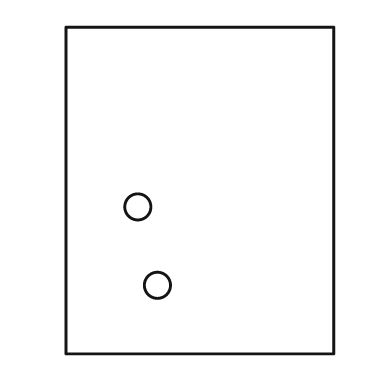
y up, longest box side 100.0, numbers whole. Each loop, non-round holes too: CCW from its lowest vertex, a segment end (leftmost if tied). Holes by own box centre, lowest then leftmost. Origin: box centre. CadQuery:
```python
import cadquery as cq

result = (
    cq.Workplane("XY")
    .moveTo(-41.0, -50.0)
    .lineTo(41.0, -50.0)
    .lineTo(41.0, 50.0)
    .lineTo(-41.0, 50.0)
    .close()
    .moveTo(-13.0, -29.0)
    .circle(4.0)
    .moveTo(-19.0, -5.0)
    .circle(4.0)
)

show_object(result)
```